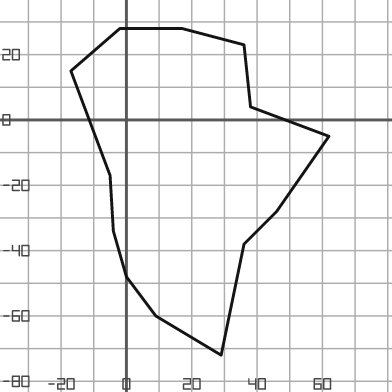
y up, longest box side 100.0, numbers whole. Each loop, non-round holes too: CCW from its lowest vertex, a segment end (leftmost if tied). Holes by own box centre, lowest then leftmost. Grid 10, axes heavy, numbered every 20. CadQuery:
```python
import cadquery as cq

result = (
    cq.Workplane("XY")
    .moveTo(29.0, -72.0)
    .lineTo(36.0, -38.0)
    .lineTo(46.0, -28.0)
    .lineTo(62.0, -5.0)
    .lineTo(38.0, 4.0)
    .lineTo(36.0, 23.0)
    .lineTo(17.0, 28.0)
    .lineTo(-2.0, 28.0)
    .lineTo(-17.0, 15.0)
    .lineTo(-5.0, -17.0)
    .lineTo(-4.0, -34.0)
    .lineTo(0.0, -48.0)
    .lineTo(9.0, -60.0)
    .close()
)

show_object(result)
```